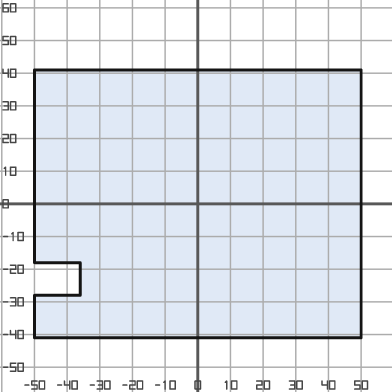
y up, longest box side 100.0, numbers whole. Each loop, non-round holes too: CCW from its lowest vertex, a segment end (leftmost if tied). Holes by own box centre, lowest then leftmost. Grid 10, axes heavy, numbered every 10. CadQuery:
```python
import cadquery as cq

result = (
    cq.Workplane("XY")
    .moveTo(-50.0, -41.0)
    .lineTo(50.0, -41.0)
    .lineTo(50.0, 41.0)
    .lineTo(-50.0, 41.0)
    .lineTo(-50.0, -18.0)
    .lineTo(-36.0, -18.0)
    .lineTo(-36.0, -28.0)
    .lineTo(-50.0, -28.0)
    .close()
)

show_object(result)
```